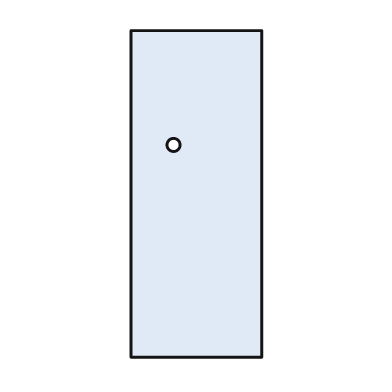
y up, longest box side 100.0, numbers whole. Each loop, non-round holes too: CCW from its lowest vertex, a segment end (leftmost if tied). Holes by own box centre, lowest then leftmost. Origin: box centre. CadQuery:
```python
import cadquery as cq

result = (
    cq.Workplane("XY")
    .moveTo(-20.0, -50.0)
    .lineTo(20.0, -50.0)
    .lineTo(20.0, 50.0)
    .lineTo(-20.0, 50.0)
    .close()
    .moveTo(-7.0, 15.0)
    .circle(2.0)
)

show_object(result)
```